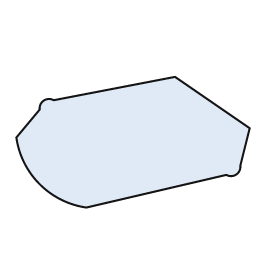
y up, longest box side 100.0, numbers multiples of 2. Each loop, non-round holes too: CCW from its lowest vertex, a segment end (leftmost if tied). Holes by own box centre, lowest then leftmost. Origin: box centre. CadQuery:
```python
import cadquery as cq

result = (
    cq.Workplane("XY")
    .moveTo(-20.0, -28.0)
    .lineTo(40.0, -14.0)
    .threePointArc((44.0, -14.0), (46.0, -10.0))
    .lineTo(50.0, 6.0)
    .lineTo(18.0, 28.0)
    .lineTo(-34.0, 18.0)
    .threePointArc((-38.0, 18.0), (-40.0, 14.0))
    .lineTo(-50.0, 2.0)
    .threePointArc((-40.0, -18.0), (-20.0, -28.0))
    .close()
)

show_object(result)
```